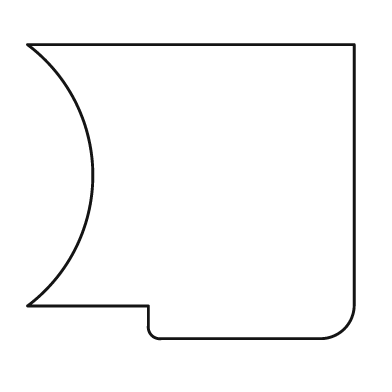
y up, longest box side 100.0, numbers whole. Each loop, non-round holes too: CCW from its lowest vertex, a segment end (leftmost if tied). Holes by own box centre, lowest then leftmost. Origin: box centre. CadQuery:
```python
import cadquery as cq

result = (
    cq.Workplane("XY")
    .moveTo(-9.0, -45.0)
    .lineTo(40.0, -45.0)
    .threePointArc((47.0, -42.0), (50.0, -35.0))
    .lineTo(50.0, 45.0)
    .lineTo(-50.0, 45.0)
    .threePointArc((-30.0, 5.0), (-50.0, -35.0))
    .lineTo(-13.0, -35.0)
    .lineTo(-13.0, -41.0)
    .threePointArc((-12.0, -44.0), (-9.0, -45.0))
    .close()
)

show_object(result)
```